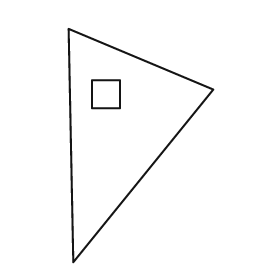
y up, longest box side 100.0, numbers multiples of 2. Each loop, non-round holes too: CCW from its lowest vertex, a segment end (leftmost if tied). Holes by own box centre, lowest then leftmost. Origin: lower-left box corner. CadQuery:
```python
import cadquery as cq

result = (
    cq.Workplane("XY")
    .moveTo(2.0, 0.0)
    .lineTo(62.0, 74.0)
    .lineTo(0.0, 100.0)
    .close()
    .moveTo(10.0, 66.0)
    .lineTo(22.0, 66.0)
    .lineTo(22.0, 78.0)
    .lineTo(10.0, 78.0)
    .close()
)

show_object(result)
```